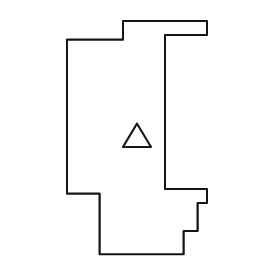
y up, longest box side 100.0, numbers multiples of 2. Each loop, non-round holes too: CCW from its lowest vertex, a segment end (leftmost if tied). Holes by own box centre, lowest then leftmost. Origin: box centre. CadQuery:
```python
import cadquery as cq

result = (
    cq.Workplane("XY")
    .moveTo(-16.0, -50.0)
    .lineTo(20.0, -50.0)
    .lineTo(20.0, -40.0)
    .lineTo(26.0, -40.0)
    .lineTo(26.0, -28.0)
    .lineTo(30.0, -28.0)
    .lineTo(30.0, -22.0)
    .lineTo(12.0, -22.0)
    .lineTo(12.0, 44.0)
    .lineTo(30.0, 44.0)
    .lineTo(30.0, 50.0)
    .lineTo(-6.0, 50.0)
    .lineTo(-6.0, 42.0)
    .lineTo(-30.0, 42.0)
    .lineTo(-30.0, -24.0)
    .lineTo(-16.0, -24.0)
    .close()
    .moveTo(-6.0, -4.0)
    .lineTo(6.0, -4.0)
    .lineTo(0.0, 6.0)
    .close()
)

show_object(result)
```